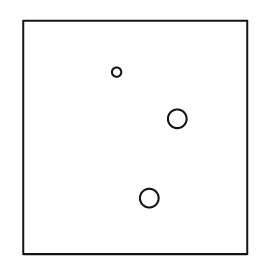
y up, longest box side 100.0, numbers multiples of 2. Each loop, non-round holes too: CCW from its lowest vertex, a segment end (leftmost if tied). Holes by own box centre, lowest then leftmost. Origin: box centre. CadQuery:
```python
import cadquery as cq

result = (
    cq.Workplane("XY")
    .moveTo(-48.0, -50.0)
    .lineTo(48.0, -50.0)
    .lineTo(48.0, 50.0)
    .lineTo(-48.0, 50.0)
    .close()
    .moveTo(6.0, -26.0)
    .circle(4.0)
    .moveTo(18.0, 8.0)
    .circle(4.0)
    .moveTo(-8.0, 28.0)
    .circle(2.0)
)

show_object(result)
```